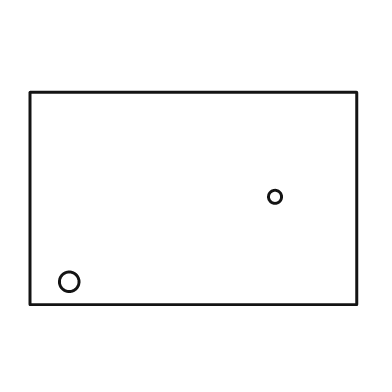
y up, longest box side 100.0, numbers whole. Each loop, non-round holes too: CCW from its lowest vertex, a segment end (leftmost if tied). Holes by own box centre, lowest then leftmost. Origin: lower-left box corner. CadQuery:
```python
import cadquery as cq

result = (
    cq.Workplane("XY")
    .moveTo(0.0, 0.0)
    .lineTo(100.0, 0.0)
    .lineTo(100.0, 65.0)
    .lineTo(0.0, 65.0)
    .close()
    .moveTo(12.0, 7.0)
    .circle(3.0)
    .moveTo(75.0, 33.0)
    .circle(2.0)
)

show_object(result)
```